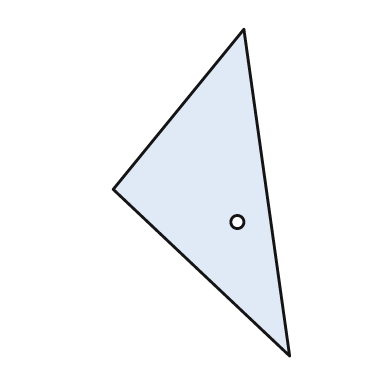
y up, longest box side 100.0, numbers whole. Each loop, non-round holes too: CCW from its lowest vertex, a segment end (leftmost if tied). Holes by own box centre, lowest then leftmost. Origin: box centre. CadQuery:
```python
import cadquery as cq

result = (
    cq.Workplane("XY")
    .moveTo(27.0, -50.0)
    .lineTo(13.0, 50.0)
    .lineTo(-27.0, 1.0)
    .close()
    .moveTo(11.0, -9.0)
    .circle(2.0)
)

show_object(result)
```